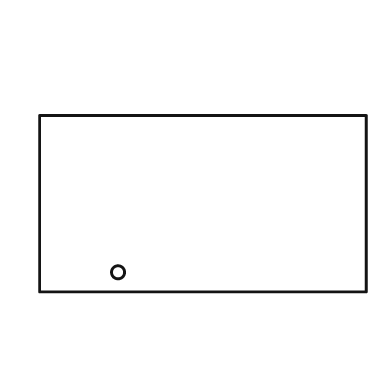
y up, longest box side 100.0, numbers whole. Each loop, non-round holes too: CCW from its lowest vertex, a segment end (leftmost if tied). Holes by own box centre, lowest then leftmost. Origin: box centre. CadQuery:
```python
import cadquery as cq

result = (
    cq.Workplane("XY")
    .moveTo(-50.0, -27.0)
    .lineTo(50.0, -27.0)
    .lineTo(50.0, 27.0)
    .lineTo(-50.0, 27.0)
    .close()
    .moveTo(-26.0, -21.0)
    .circle(2.0)
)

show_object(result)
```